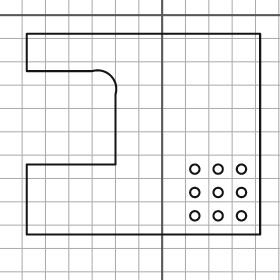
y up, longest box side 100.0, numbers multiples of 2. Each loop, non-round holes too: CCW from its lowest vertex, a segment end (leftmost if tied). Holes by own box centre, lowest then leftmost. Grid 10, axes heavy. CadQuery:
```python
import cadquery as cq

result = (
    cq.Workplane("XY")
    .moveTo(-58.0, -94.0)
    .lineTo(42.0, -94.0)
    .lineTo(42.0, -8.0)
    .lineTo(-58.0, -8.0)
    .lineTo(-58.0, -24.0)
    .lineTo(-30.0, -24.0)
    .threePointArc((-22.0, -26.0), (-20.0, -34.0))
    .lineTo(-20.0, -64.0)
    .lineTo(-58.0, -64.0)
    .close()
    .moveTo(14.0, -86.0)
    .circle(2.0)
    .moveTo(24.0, -86.0)
    .circle(2.0)
    .moveTo(34.0, -86.0)
    .circle(2.0)
    .moveTo(14.0, -76.0)
    .circle(2.0)
    .moveTo(24.0, -76.0)
    .circle(2.0)
    .moveTo(34.0, -76.0)
    .circle(2.0)
    .moveTo(14.0, -66.0)
    .circle(2.0)
    .moveTo(24.0, -66.0)
    .circle(2.0)
    .moveTo(34.0, -66.0)
    .circle(2.0)
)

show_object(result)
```